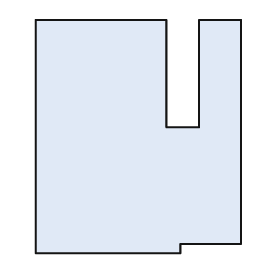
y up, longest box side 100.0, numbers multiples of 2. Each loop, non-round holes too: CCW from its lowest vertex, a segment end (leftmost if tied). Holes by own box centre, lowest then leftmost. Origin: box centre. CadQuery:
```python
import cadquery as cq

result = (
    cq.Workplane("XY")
    .moveTo(-44.0, -50.0)
    .lineTo(18.0, -50.0)
    .lineTo(18.0, -46.0)
    .lineTo(44.0, -46.0)
    .lineTo(44.0, 50.0)
    .lineTo(26.0, 50.0)
    .lineTo(26.0, 4.0)
    .lineTo(12.0, 4.0)
    .lineTo(12.0, 50.0)
    .lineTo(-44.0, 50.0)
    .close()
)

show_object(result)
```